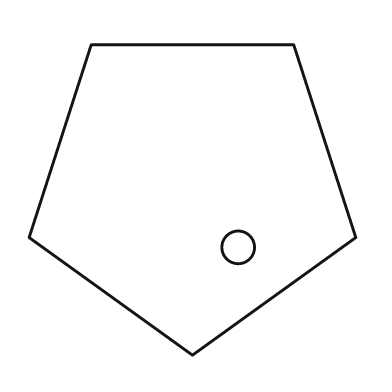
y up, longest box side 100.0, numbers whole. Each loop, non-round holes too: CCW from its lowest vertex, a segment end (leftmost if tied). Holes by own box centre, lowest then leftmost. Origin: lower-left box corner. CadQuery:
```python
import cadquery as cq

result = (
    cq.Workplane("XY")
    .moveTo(50.0, 0.0)
    .lineTo(100.0, 36.0)
    .lineTo(81.0, 95.0)
    .lineTo(19.0, 95.0)
    .lineTo(0.0, 36.0)
    .close()
    .moveTo(64.0, 33.0)
    .circle(5.0)
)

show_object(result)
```